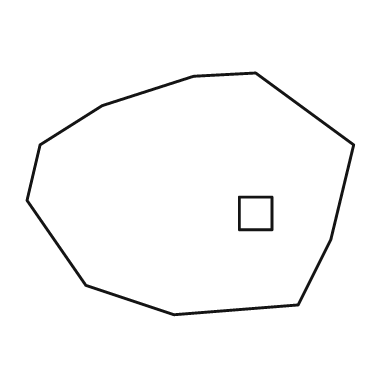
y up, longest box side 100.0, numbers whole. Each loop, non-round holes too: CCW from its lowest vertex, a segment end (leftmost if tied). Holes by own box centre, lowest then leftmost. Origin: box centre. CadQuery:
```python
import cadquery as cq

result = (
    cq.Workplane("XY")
    .moveTo(-5.0, -37.0)
    .lineTo(33.0, -34.0)
    .lineTo(43.0, -14.0)
    .lineTo(50.0, 15.0)
    .lineTo(20.0, 37.0)
    .lineTo(1.0, 36.0)
    .lineTo(-27.0, 27.0)
    .lineTo(-46.0, 15.0)
    .lineTo(-50.0, -2.0)
    .lineTo(-32.0, -28.0)
    .close()
    .moveTo(15.0, -11.0)
    .lineTo(25.0, -11.0)
    .lineTo(25.0, -1.0)
    .lineTo(15.0, -1.0)
    .close()
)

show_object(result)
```